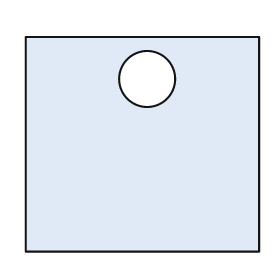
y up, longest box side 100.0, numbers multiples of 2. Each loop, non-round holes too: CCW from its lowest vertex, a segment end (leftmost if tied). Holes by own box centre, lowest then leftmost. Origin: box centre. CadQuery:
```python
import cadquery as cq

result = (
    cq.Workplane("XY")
    .moveTo(-50.0, -46.0)
    .lineTo(50.0, -46.0)
    .lineTo(50.0, 46.0)
    .lineTo(-50.0, 46.0)
    .close()
    .moveTo(2.0, 28.0)
    .circle(12.0)
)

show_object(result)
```